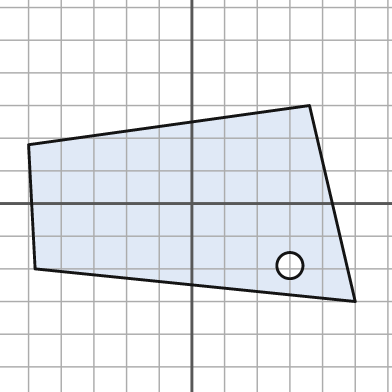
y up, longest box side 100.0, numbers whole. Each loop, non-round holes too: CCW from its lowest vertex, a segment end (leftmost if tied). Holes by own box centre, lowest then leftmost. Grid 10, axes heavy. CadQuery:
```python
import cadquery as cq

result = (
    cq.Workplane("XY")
    .moveTo(50.0, -30.0)
    .lineTo(36.0, 30.0)
    .lineTo(-50.0, 18.0)
    .lineTo(-48.0, -20.0)
    .close()
    .moveTo(30.0, -19.0)
    .circle(4.0)
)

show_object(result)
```